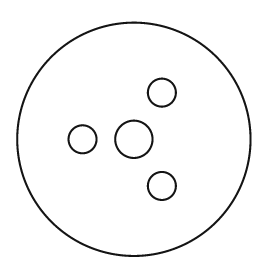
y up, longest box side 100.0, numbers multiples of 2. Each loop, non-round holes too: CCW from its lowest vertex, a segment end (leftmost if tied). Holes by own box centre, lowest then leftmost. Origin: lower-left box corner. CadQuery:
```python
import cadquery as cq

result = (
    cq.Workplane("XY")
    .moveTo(50.0, 50.0)
    .circle(50.0)
    .moveTo(62.0, 30.0)
    .circle(6.0)
    .moveTo(28.0, 50.0)
    .circle(6.0)
    .moveTo(50.0, 50.0)
    .circle(8.0)
    .moveTo(62.0, 70.0)
    .circle(6.0)
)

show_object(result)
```